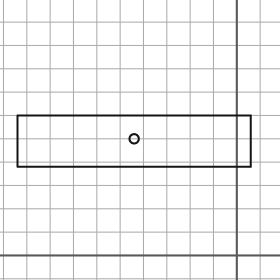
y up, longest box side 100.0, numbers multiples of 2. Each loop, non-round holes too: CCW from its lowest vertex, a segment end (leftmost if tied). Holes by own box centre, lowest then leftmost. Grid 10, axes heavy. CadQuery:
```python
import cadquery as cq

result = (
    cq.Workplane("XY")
    .moveTo(-94.0, 38.0)
    .lineTo(6.0, 38.0)
    .lineTo(6.0, 60.0)
    .lineTo(-94.0, 60.0)
    .close()
    .moveTo(-44.0, 50.0)
    .circle(2.0)
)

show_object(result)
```